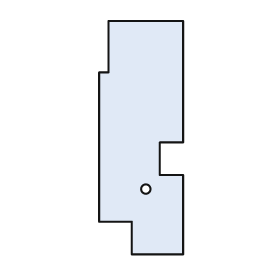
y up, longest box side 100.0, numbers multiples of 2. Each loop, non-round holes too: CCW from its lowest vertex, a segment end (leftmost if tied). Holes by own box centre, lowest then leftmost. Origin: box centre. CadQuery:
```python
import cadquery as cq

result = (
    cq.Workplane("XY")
    .moveTo(-4.0, -50.0)
    .lineTo(18.0, -50.0)
    .lineTo(18.0, -16.0)
    .lineTo(8.0, -16.0)
    .lineTo(8.0, -2.0)
    .lineTo(18.0, -2.0)
    .lineTo(18.0, 50.0)
    .lineTo(-14.0, 50.0)
    .lineTo(-14.0, 28.0)
    .lineTo(-18.0, 28.0)
    .lineTo(-18.0, -36.0)
    .lineTo(-4.0, -36.0)
    .close()
    .moveTo(2.0, -22.0)
    .circle(2.0)
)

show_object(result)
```